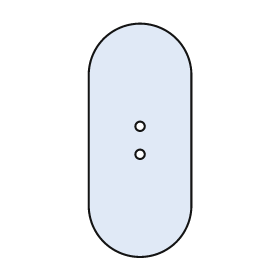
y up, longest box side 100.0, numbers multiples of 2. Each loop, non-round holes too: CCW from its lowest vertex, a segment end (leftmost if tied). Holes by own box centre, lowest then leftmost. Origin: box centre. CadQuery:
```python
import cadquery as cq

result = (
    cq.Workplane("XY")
    .moveTo(-22.0, -28.0)
    .threePointArc((0.0, -50.0), (22.0, -28.0))
    .lineTo(22.0, 28.0)
    .threePointArc((0.0, 50.0), (-22.0, 28.0))
    .close()
    .moveTo(0.0, -6.0)
    .circle(2.0)
    .moveTo(0.0, 6.0)
    .circle(2.0)
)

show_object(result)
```